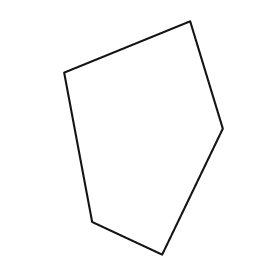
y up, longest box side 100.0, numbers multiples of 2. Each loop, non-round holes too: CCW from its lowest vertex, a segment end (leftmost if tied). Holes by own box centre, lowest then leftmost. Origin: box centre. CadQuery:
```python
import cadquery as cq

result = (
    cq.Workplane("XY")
    .moveTo(8.0, -50.0)
    .lineTo(34.0, 4.0)
    .lineTo(20.0, 50.0)
    .lineTo(-34.0, 28.0)
    .lineTo(-22.0, -36.0)
    .close()
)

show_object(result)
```